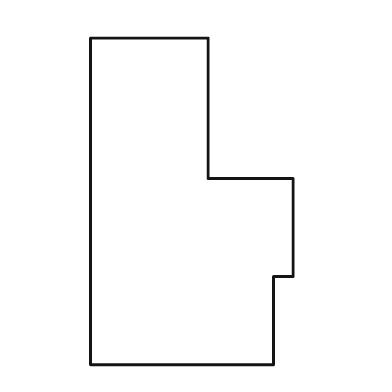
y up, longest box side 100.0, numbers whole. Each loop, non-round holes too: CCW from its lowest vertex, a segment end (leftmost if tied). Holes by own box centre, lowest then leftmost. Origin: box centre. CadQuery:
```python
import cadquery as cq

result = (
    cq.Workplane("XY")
    .moveTo(-31.0, -50.0)
    .lineTo(25.0, -50.0)
    .lineTo(25.0, -23.0)
    .lineTo(31.0, -23.0)
    .lineTo(31.0, 7.0)
    .lineTo(5.0, 7.0)
    .lineTo(5.0, 50.0)
    .lineTo(-31.0, 50.0)
    .close()
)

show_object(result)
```